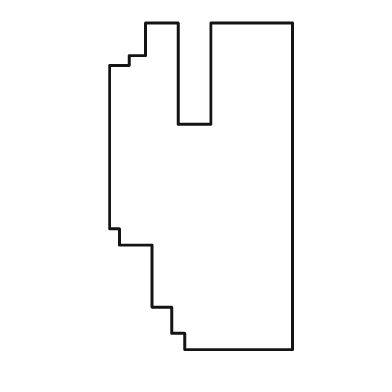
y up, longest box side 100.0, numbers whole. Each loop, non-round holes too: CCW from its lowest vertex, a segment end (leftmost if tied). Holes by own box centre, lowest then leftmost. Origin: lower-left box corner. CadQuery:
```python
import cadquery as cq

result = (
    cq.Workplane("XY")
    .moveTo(23.0, 0.0)
    .lineTo(56.0, 0.0)
    .lineTo(56.0, 100.0)
    .lineTo(31.0, 100.0)
    .lineTo(31.0, 69.0)
    .lineTo(21.0, 69.0)
    .lineTo(21.0, 100.0)
    .lineTo(11.0, 100.0)
    .lineTo(11.0, 90.0)
    .lineTo(6.0, 90.0)
    .lineTo(6.0, 87.0)
    .lineTo(0.0, 87.0)
    .lineTo(0.0, 37.0)
    .lineTo(3.0, 37.0)
    .lineTo(3.0, 32.0)
    .lineTo(13.0, 32.0)
    .lineTo(13.0, 13.0)
    .lineTo(19.0, 13.0)
    .lineTo(19.0, 5.0)
    .lineTo(23.0, 5.0)
    .close()
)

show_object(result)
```